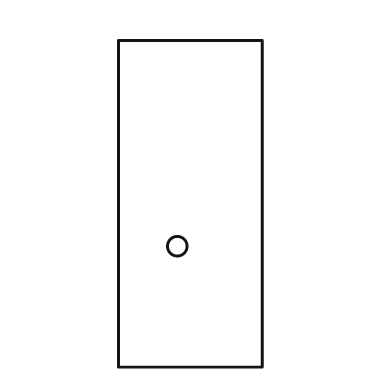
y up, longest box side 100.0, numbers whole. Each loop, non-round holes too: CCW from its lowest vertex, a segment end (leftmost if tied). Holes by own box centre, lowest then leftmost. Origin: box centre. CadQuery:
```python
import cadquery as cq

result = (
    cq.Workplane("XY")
    .moveTo(-22.0, -50.0)
    .lineTo(22.0, -50.0)
    .lineTo(22.0, 50.0)
    .lineTo(-22.0, 50.0)
    .close()
    .moveTo(-4.0, -13.0)
    .circle(3.0)
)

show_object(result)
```